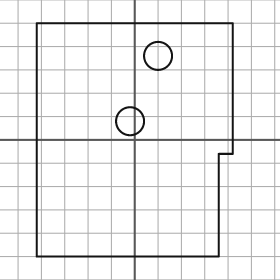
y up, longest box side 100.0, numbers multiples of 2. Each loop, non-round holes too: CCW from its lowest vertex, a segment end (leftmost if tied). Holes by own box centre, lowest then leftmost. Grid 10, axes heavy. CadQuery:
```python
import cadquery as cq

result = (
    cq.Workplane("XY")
    .moveTo(-42.0, -50.0)
    .lineTo(36.0, -50.0)
    .lineTo(36.0, -6.0)
    .lineTo(42.0, -6.0)
    .lineTo(42.0, 50.0)
    .lineTo(-42.0, 50.0)
    .close()
    .moveTo(-2.0, 8.0)
    .circle(6.0)
    .moveTo(10.0, 36.0)
    .circle(6.0)
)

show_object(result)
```